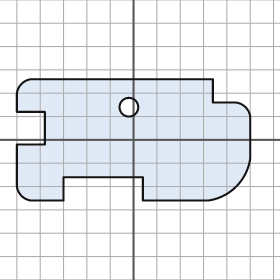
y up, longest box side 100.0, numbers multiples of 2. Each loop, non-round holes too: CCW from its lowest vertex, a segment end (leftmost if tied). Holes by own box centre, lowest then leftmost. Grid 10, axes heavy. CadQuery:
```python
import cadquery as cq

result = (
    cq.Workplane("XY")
    .moveTo(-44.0, -26.0)
    .lineTo(-30.0, -26.0)
    .lineTo(-30.0, -16.0)
    .lineTo(4.0, -16.0)
    .lineTo(4.0, -26.0)
    .lineTo(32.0, -26.0)
    .threePointArc((44.0, -20.0), (50.0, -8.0))
    .lineTo(50.0, 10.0)
    .threePointArc((48.0, 14.0), (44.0, 16.0))
    .lineTo(34.0, 16.0)
    .lineTo(34.0, 26.0)
    .lineTo(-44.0, 26.0)
    .threePointArc((-48.0, 24.0), (-50.0, 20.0))
    .lineTo(-50.0, 12.0)
    .lineTo(-38.0, 12.0)
    .lineTo(-38.0, -2.0)
    .lineTo(-50.0, -2.0)
    .lineTo(-50.0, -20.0)
    .threePointArc((-48.0, -24.0), (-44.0, -26.0))
    .close()
    .moveTo(-2.0, 14.0)
    .circle(4.0)
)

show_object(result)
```